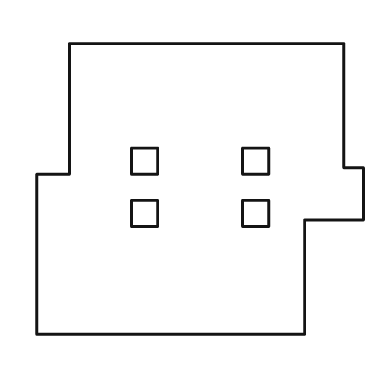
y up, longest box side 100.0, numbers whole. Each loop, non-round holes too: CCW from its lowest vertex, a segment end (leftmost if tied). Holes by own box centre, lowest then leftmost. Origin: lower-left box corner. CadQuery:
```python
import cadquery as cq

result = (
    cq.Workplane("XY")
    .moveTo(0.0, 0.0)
    .lineTo(82.0, 0.0)
    .lineTo(82.0, 35.0)
    .lineTo(100.0, 35.0)
    .lineTo(100.0, 51.0)
    .lineTo(94.0, 51.0)
    .lineTo(94.0, 89.0)
    .lineTo(10.0, 89.0)
    .lineTo(10.0, 49.0)
    .lineTo(0.0, 49.0)
    .close()
    .moveTo(29.0, 33.0)
    .lineTo(37.0, 33.0)
    .lineTo(37.0, 41.0)
    .lineTo(29.0, 41.0)
    .close()
    .moveTo(63.0, 33.0)
    .lineTo(71.0, 33.0)
    .lineTo(71.0, 41.0)
    .lineTo(63.0, 41.0)
    .close()
    .moveTo(29.0, 49.0)
    .lineTo(37.0, 49.0)
    .lineTo(37.0, 57.0)
    .lineTo(29.0, 57.0)
    .close()
    .moveTo(63.0, 49.0)
    .lineTo(71.0, 49.0)
    .lineTo(71.0, 57.0)
    .lineTo(63.0, 57.0)
    .close()
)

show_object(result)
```